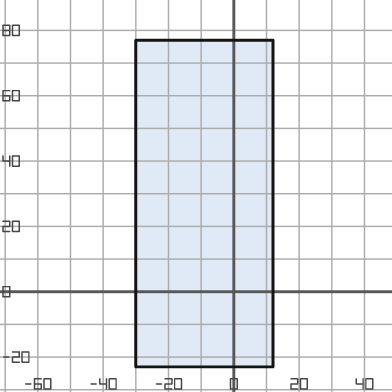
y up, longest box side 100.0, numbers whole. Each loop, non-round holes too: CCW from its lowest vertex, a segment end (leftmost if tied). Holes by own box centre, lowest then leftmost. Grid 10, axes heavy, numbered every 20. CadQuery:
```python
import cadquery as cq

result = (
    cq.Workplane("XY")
    .moveTo(-30.0, -23.0)
    .lineTo(12.0, -23.0)
    .lineTo(12.0, 77.0)
    .lineTo(-30.0, 77.0)
    .close()
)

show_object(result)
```